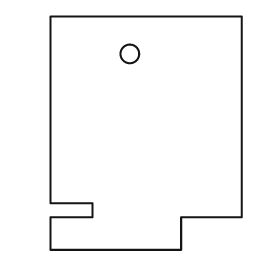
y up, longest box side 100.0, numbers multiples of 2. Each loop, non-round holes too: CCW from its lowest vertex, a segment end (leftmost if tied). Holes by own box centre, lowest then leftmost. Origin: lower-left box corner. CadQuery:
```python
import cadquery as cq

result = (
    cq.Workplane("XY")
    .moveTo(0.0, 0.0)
    .lineTo(56.0, 0.0)
    .lineTo(56.0, 14.0)
    .lineTo(82.0, 14.0)
    .lineTo(82.0, 100.0)
    .lineTo(0.0, 100.0)
    .lineTo(0.0, 20.0)
    .lineTo(18.0, 20.0)
    .lineTo(18.0, 14.0)
    .lineTo(0.0, 14.0)
    .close()
    .moveTo(34.0, 84.0)
    .circle(4.0)
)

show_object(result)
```